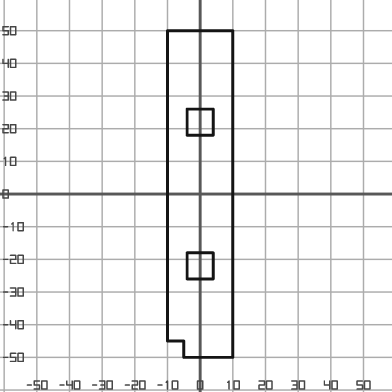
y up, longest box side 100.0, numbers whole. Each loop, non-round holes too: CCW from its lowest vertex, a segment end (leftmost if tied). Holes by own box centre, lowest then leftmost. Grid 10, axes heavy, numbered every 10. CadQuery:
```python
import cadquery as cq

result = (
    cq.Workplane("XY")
    .moveTo(-5.0, -50.0)
    .lineTo(10.0, -50.0)
    .lineTo(10.0, 50.0)
    .lineTo(-10.0, 50.0)
    .lineTo(-10.0, -45.0)
    .lineTo(-5.0, -45.0)
    .close()
    .moveTo(-4.0, -26.0)
    .lineTo(4.0, -26.0)
    .lineTo(4.0, -18.0)
    .lineTo(-4.0, -18.0)
    .close()
    .moveTo(-4.0, 18.0)
    .lineTo(4.0, 18.0)
    .lineTo(4.0, 26.0)
    .lineTo(-4.0, 26.0)
    .close()
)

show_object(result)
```